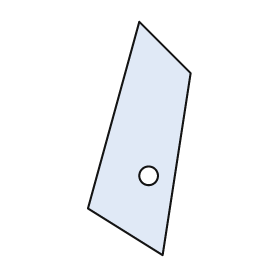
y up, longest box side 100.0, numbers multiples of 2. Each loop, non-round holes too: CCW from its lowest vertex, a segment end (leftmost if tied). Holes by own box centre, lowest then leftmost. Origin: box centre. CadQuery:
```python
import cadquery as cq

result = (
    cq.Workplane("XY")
    .moveTo(10.0, -50.0)
    .lineTo(22.0, 28.0)
    .lineTo(0.0, 50.0)
    .lineTo(-22.0, -30.0)
    .close()
    .moveTo(4.0, -16.0)
    .circle(4.0)
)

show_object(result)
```